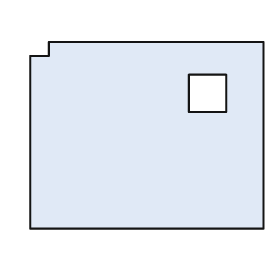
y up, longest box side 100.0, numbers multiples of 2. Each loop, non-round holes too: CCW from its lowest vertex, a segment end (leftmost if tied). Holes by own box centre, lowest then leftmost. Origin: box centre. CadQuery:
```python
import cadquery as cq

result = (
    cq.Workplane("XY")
    .moveTo(-50.0, -40.0)
    .lineTo(50.0, -40.0)
    .lineTo(50.0, 40.0)
    .lineTo(-42.0, 40.0)
    .lineTo(-42.0, 34.0)
    .lineTo(-50.0, 34.0)
    .close()
    .moveTo(18.0, 10.0)
    .lineTo(34.0, 10.0)
    .lineTo(34.0, 26.0)
    .lineTo(18.0, 26.0)
    .close()
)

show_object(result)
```